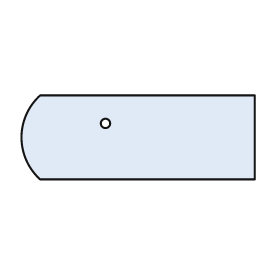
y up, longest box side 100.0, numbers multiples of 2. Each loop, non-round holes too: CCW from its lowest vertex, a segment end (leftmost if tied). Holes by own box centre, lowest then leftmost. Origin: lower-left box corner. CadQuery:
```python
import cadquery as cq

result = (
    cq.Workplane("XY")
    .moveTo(8.0, 0.0)
    .lineTo(100.0, 0.0)
    .lineTo(100.0, 36.0)
    .lineTo(8.0, 36.0)
    .threePointArc((0.0, 18.0), (8.0, 0.0))
    .close()
    .moveTo(36.0, 24.0)
    .circle(2.0)
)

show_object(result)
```